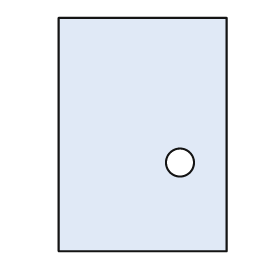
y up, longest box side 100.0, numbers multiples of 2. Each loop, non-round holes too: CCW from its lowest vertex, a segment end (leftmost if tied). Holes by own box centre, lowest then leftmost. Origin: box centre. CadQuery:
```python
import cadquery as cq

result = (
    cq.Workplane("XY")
    .moveTo(-36.0, -50.0)
    .lineTo(36.0, -50.0)
    .lineTo(36.0, 50.0)
    .lineTo(-36.0, 50.0)
    .close()
    .moveTo(16.0, -12.0)
    .circle(6.0)
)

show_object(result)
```